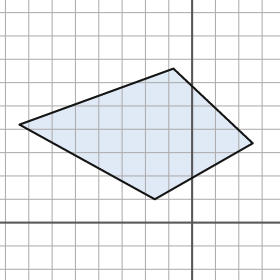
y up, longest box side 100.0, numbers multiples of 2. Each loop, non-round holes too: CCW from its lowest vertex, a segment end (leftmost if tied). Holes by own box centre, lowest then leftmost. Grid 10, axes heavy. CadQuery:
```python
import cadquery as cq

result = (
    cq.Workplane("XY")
    .moveTo(-16.0, 10.0)
    .lineTo(26.0, 34.0)
    .lineTo(-8.0, 66.0)
    .lineTo(-74.0, 42.0)
    .close()
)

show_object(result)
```